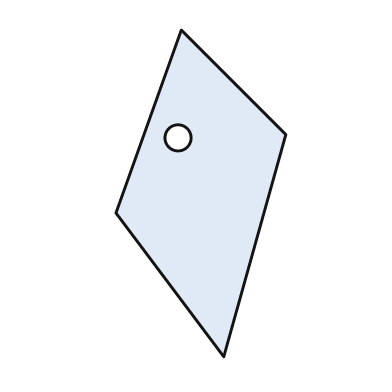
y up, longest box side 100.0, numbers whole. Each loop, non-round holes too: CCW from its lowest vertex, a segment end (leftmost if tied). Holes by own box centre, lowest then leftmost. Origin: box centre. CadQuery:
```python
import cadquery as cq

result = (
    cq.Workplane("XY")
    .moveTo(7.0, -50.0)
    .lineTo(26.0, 18.0)
    .lineTo(-6.0, 50.0)
    .lineTo(-26.0, -6.0)
    .close()
    .moveTo(-7.0, 17.0)
    .circle(4.0)
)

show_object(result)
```